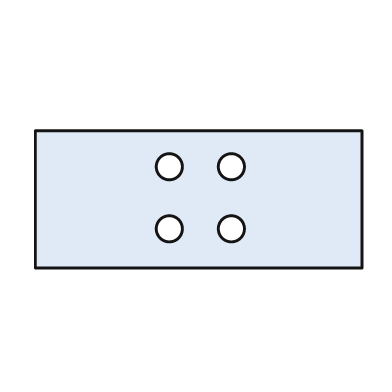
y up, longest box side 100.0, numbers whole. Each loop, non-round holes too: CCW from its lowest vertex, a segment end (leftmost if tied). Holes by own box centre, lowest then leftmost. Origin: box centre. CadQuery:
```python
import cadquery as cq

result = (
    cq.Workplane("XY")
    .moveTo(-50.0, -21.0)
    .lineTo(50.0, -21.0)
    .lineTo(50.0, 21.0)
    .lineTo(-50.0, 21.0)
    .close()
    .moveTo(-9.0, -9.0)
    .circle(4.0)
    .moveTo(10.0, -9.0)
    .circle(4.0)
    .moveTo(-9.0, 10.0)
    .circle(4.0)
    .moveTo(10.0, 10.0)
    .circle(4.0)
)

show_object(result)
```